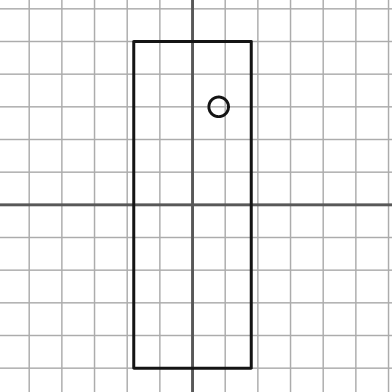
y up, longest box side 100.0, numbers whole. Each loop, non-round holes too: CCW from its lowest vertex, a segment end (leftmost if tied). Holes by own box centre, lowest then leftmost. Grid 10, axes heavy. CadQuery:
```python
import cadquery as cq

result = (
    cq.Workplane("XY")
    .moveTo(-18.0, -50.0)
    .lineTo(18.0, -50.0)
    .lineTo(18.0, 50.0)
    .lineTo(-18.0, 50.0)
    .close()
    .moveTo(8.0, 30.0)
    .circle(3.0)
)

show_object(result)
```